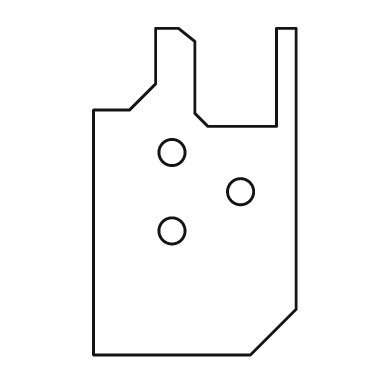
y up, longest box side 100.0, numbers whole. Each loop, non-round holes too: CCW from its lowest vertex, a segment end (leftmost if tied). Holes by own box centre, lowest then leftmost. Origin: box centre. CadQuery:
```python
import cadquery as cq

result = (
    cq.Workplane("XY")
    .moveTo(-31.0, -50.0)
    .lineTo(17.0, -50.0)
    .lineTo(31.0, -36.0)
    .lineTo(31.0, 50.0)
    .lineTo(25.0, 50.0)
    .lineTo(25.0, 20.0)
    .lineTo(4.0, 20.0)
    .lineTo(0.0, 24.0)
    .lineTo(0.0, 46.0)
    .lineTo(-5.0, 50.0)
    .lineTo(-12.0, 50.0)
    .lineTo(-12.0, 33.0)
    .lineTo(-20.0, 25.0)
    .lineTo(-31.0, 25.0)
    .close()
    .moveTo(-7.0, -12.0)
    .circle(4.0)
    .moveTo(14.0, 0.0)
    .circle(4.0)
    .moveTo(-7.0, 12.0)
    .circle(4.0)
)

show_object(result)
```